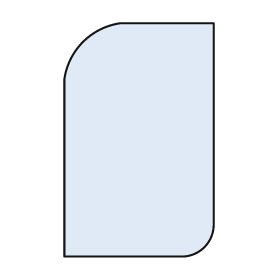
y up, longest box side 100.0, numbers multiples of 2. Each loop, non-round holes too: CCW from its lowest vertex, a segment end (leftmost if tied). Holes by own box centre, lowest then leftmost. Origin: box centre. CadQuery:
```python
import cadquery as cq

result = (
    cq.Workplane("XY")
    .moveTo(-32.0, -50.0)
    .lineTo(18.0, -50.0)
    .threePointArc((28.0, -46.0), (32.0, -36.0))
    .lineTo(32.0, 50.0)
    .lineTo(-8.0, 50.0)
    .threePointArc((-24.0, 42.0), (-32.0, 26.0))
    .close()
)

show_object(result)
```